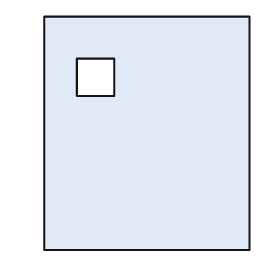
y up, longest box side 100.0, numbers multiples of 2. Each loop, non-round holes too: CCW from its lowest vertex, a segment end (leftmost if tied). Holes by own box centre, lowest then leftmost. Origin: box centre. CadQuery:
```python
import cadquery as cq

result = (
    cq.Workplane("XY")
    .moveTo(-44.0, -50.0)
    .lineTo(44.0, -50.0)
    .lineTo(44.0, 50.0)
    .lineTo(-44.0, 50.0)
    .close()
    .moveTo(-30.0, 16.0)
    .lineTo(-14.0, 16.0)
    .lineTo(-14.0, 32.0)
    .lineTo(-30.0, 32.0)
    .close()
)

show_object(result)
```